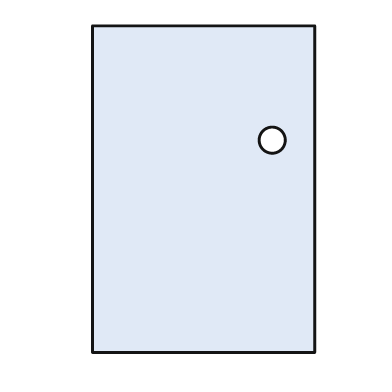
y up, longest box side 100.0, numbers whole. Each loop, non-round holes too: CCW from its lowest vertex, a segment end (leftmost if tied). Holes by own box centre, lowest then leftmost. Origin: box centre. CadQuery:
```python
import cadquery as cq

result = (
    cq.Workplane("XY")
    .moveTo(-34.0, -50.0)
    .lineTo(34.0, -50.0)
    .lineTo(34.0, 50.0)
    .lineTo(-34.0, 50.0)
    .close()
    .moveTo(21.0, 15.0)
    .circle(4.0)
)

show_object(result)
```